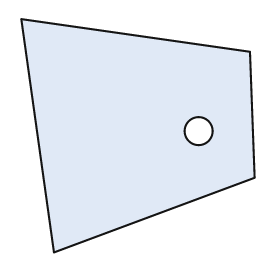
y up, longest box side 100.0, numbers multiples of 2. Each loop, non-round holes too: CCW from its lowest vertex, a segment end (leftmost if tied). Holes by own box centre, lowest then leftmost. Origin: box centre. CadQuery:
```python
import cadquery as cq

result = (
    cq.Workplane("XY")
    .moveTo(-36.0, -50.0)
    .lineTo(50.0, -18.0)
    .lineTo(48.0, 36.0)
    .lineTo(-50.0, 50.0)
    .close()
    .moveTo(26.0, 2.0)
    .circle(6.0)
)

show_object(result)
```